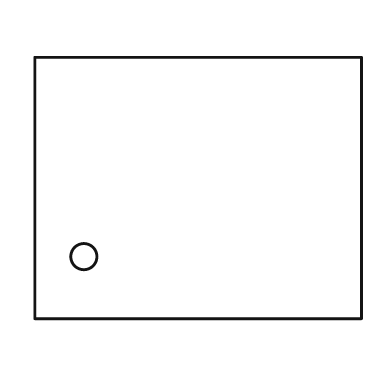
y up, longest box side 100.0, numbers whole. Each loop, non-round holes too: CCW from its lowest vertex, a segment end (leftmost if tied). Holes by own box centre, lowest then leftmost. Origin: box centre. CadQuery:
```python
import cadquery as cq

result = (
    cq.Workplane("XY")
    .moveTo(-50.0, -40.0)
    .lineTo(50.0, -40.0)
    .lineTo(50.0, 40.0)
    .lineTo(-50.0, 40.0)
    .close()
    .moveTo(-35.0, -21.0)
    .circle(4.0)
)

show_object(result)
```